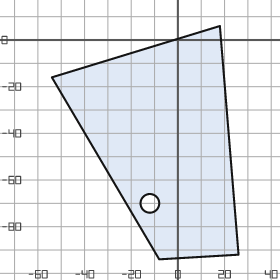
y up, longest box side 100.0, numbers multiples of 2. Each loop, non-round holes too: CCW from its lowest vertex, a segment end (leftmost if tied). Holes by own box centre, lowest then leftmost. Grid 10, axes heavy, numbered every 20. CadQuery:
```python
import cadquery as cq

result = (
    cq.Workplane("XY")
    .moveTo(-8.0, -94.0)
    .lineTo(26.0, -92.0)
    .lineTo(18.0, 6.0)
    .lineTo(-54.0, -16.0)
    .close()
    .moveTo(-12.0, -70.0)
    .circle(4.0)
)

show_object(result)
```